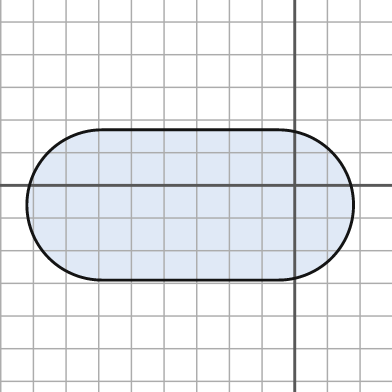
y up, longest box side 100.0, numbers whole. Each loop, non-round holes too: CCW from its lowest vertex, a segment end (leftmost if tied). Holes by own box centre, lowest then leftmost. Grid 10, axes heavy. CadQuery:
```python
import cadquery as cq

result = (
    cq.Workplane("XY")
    .moveTo(-59.0, -29.0)
    .lineTo(-5.0, -29.0)
    .threePointArc((18.0, -6.0), (-5.0, 17.0))
    .lineTo(-59.0, 17.0)
    .threePointArc((-82.0, -6.0), (-59.0, -29.0))
    .close()
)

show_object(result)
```